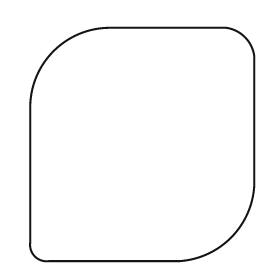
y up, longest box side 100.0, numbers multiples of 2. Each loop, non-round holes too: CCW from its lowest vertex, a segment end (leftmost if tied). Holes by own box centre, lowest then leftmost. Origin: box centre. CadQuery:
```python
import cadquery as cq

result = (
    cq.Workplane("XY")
    .moveTo(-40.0, -50.0)
    .lineTo(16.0, -50.0)
    .threePointArc((38.0, -40.0), (48.0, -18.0))
    .lineTo(48.0, 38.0)
    .threePointArc((44.0, 46.0), (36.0, 50.0))
    .lineTo(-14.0, 50.0)
    .threePointArc((-38.0, 40.0), (-48.0, 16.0))
    .lineTo(-48.0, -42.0)
    .threePointArc((-46.0, -48.0), (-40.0, -50.0))
    .close()
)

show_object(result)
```